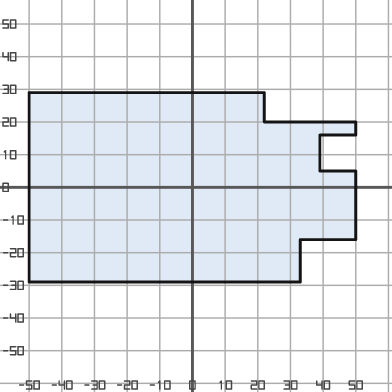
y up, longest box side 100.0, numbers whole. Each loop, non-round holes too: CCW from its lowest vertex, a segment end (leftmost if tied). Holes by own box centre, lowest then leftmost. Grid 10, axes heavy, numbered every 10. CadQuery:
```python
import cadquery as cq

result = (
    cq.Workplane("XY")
    .moveTo(-50.0, -29.0)
    .lineTo(33.0, -29.0)
    .lineTo(33.0, -16.0)
    .lineTo(50.0, -16.0)
    .lineTo(50.0, 5.0)
    .lineTo(39.0, 5.0)
    .lineTo(39.0, 16.0)
    .lineTo(50.0, 16.0)
    .lineTo(50.0, 20.0)
    .lineTo(22.0, 20.0)
    .lineTo(22.0, 29.0)
    .lineTo(-50.0, 29.0)
    .close()
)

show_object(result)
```